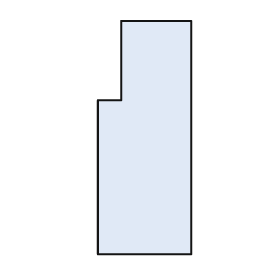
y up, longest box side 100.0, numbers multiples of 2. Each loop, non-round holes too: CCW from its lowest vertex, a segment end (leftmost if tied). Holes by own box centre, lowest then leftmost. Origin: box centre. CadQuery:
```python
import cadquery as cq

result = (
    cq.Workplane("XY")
    .moveTo(-20.0, -50.0)
    .lineTo(20.0, -50.0)
    .lineTo(20.0, 50.0)
    .lineTo(-10.0, 50.0)
    .lineTo(-10.0, 16.0)
    .lineTo(-20.0, 16.0)
    .close()
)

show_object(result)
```